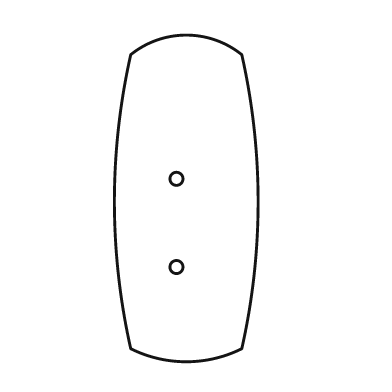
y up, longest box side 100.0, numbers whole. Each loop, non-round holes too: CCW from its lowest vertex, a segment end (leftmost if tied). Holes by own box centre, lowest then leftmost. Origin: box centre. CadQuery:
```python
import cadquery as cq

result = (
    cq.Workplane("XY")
    .moveTo(-17.0, -46.0)
    .threePointArc((0.0, -50.0), (17.0, -46.0))
    .threePointArc((22.0, -1.0), (17.0, 44.0))
    .threePointArc((0.0, 50.0), (-17.0, 44.0))
    .threePointArc((-22.0, -1.0), (-17.0, -46.0))
    .close()
    .moveTo(-3.0, -21.0)
    .circle(2.0)
    .moveTo(-3.0, 6.0)
    .circle(2.0)
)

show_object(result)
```